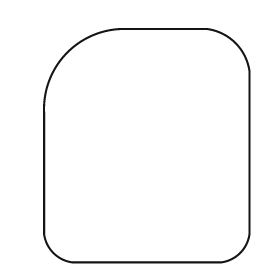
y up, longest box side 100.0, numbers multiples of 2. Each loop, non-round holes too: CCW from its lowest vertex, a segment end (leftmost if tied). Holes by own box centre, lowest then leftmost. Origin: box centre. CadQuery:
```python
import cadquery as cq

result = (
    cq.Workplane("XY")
    .moveTo(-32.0, -50.0)
    .lineTo(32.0, -50.0)
    .threePointArc((40.0, -46.0), (44.0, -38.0))
    .lineTo(44.0, 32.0)
    .threePointArc((38.0, 44.0), (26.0, 50.0))
    .lineTo(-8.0, 50.0)
    .threePointArc((-34.0, 40.0), (-44.0, 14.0))
    .lineTo(-44.0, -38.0)
    .threePointArc((-40.0, -46.0), (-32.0, -50.0))
    .close()
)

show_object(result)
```